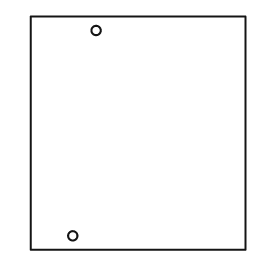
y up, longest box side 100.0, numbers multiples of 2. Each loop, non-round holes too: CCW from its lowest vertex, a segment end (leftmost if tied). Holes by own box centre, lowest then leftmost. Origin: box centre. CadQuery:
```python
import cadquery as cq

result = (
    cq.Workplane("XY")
    .moveTo(-46.0, -50.0)
    .lineTo(46.0, -50.0)
    .lineTo(46.0, 50.0)
    .lineTo(-46.0, 50.0)
    .close()
    .moveTo(-28.0, -44.0)
    .circle(2.0)
    .moveTo(-18.0, 44.0)
    .circle(2.0)
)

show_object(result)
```